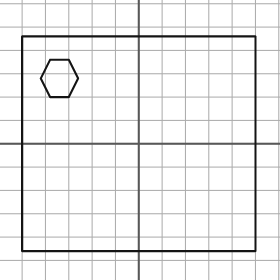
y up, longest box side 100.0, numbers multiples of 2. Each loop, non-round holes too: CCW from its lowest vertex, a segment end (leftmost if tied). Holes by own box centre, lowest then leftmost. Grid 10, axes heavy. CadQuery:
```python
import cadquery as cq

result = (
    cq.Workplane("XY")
    .moveTo(-50.0, -46.0)
    .lineTo(50.0, -46.0)
    .lineTo(50.0, 46.0)
    .lineTo(-50.0, 46.0)
    .close()
    .moveTo(-38.0, 20.0)
    .lineTo(-30.0, 20.0)
    .lineTo(-26.0, 28.0)
    .lineTo(-30.0, 36.0)
    .lineTo(-38.0, 36.0)
    .lineTo(-42.0, 28.0)
    .close()
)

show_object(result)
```